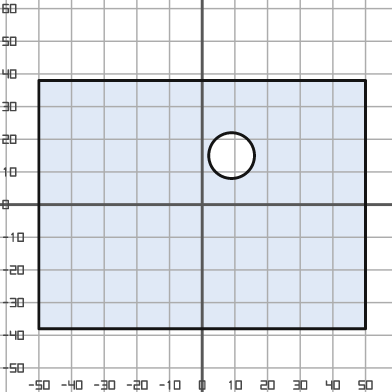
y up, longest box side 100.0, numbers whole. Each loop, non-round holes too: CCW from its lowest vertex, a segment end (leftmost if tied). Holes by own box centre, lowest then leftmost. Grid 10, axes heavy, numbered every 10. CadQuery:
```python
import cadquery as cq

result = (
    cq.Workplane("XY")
    .moveTo(-50.0, -38.0)
    .lineTo(50.0, -38.0)
    .lineTo(50.0, 38.0)
    .lineTo(-50.0, 38.0)
    .close()
    .moveTo(9.0, 15.0)
    .circle(7.0)
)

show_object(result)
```